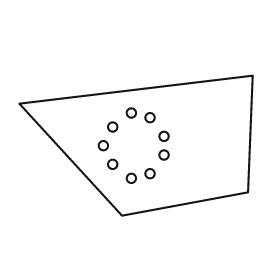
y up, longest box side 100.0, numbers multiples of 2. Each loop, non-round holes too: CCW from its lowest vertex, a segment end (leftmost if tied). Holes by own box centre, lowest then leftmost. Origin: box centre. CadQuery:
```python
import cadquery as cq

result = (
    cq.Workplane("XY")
    .moveTo(-6.0, -30.0)
    .lineTo(48.0, -20.0)
    .lineTo(50.0, 30.0)
    .lineTo(-50.0, 18.0)
    .close()
    .moveTo(-2.0, -14.0)
    .circle(2.0)
    .moveTo(6.0, -12.0)
    .circle(2.0)
    .moveTo(-10.0, -8.0)
    .circle(2.0)
    .moveTo(12.0, -4.0)
    .circle(2.0)
    .moveTo(-14.0, 0.0)
    .circle(2.0)
    .moveTo(12.0, 4.0)
    .circle(2.0)
    .moveTo(-10.0, 8.0)
    .circle(2.0)
    .moveTo(6.0, 12.0)
    .circle(2.0)
    .moveTo(-2.0, 14.0)
    .circle(2.0)
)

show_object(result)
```